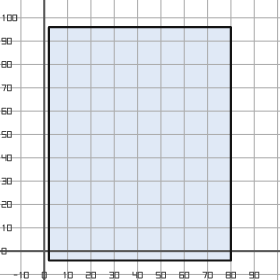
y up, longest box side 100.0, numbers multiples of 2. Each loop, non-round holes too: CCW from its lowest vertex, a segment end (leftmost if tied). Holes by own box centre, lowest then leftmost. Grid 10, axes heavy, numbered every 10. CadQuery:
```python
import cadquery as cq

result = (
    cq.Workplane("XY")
    .moveTo(2.0, -4.0)
    .lineTo(80.0, -4.0)
    .lineTo(80.0, 96.0)
    .lineTo(2.0, 96.0)
    .close()
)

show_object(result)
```